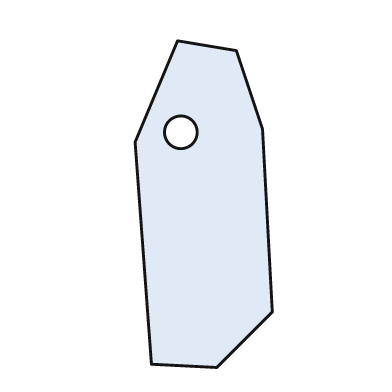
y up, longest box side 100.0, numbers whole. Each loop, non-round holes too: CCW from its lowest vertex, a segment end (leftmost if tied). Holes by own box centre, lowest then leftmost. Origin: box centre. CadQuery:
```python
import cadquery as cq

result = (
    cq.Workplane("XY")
    .moveTo(4.0, -50.0)
    .lineTo(21.0, -33.0)
    .lineTo(18.0, 23.0)
    .lineTo(10.0, 47.0)
    .lineTo(-8.0, 50.0)
    .lineTo(-21.0, 19.0)
    .lineTo(-16.0, -49.0)
    .close()
    .moveTo(-7.0, 22.0)
    .circle(5.0)
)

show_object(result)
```